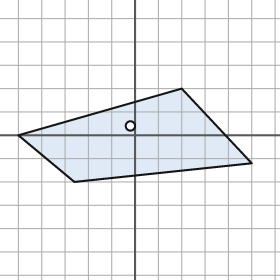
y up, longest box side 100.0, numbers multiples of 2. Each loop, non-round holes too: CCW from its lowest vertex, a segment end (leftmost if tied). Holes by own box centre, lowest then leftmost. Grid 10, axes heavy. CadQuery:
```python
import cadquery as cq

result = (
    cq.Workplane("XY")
    .moveTo(-26.0, -20.0)
    .lineTo(50.0, -12.0)
    .lineTo(20.0, 20.0)
    .lineTo(-50.0, 0.0)
    .close()
    .moveTo(-2.0, 4.0)
    .circle(2.0)
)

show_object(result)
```